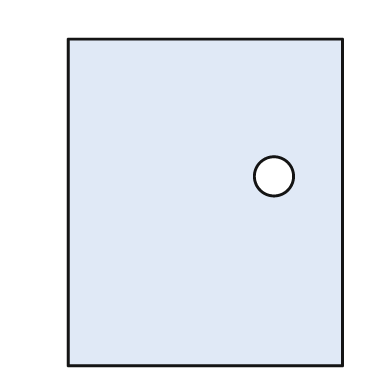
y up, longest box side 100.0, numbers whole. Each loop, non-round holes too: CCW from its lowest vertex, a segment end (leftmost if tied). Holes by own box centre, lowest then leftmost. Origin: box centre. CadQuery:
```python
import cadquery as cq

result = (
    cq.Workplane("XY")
    .moveTo(-42.0, -50.0)
    .lineTo(42.0, -50.0)
    .lineTo(42.0, 50.0)
    .lineTo(-42.0, 50.0)
    .close()
    .moveTo(21.0, 8.0)
    .circle(6.0)
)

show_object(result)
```